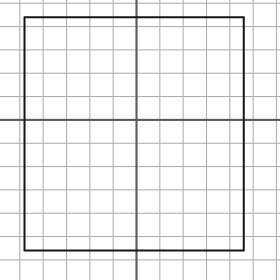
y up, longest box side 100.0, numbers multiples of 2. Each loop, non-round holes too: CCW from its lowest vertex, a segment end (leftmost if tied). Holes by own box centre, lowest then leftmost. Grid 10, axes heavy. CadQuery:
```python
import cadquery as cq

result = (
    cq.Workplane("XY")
    .moveTo(-48.0, -56.0)
    .lineTo(46.0, -56.0)
    .lineTo(46.0, 44.0)
    .lineTo(-48.0, 44.0)
    .close()
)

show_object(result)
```